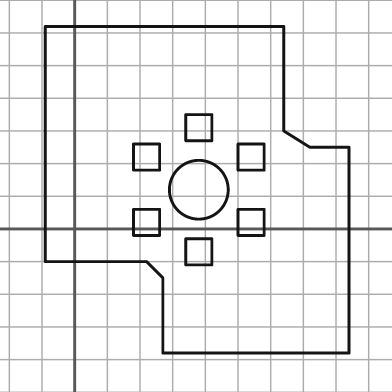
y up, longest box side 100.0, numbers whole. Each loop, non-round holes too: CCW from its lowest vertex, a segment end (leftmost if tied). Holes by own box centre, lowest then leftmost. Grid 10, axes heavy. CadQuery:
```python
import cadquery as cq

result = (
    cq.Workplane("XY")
    .moveTo(27.0, -38.0)
    .lineTo(84.0, -38.0)
    .lineTo(84.0, 25.0)
    .lineTo(72.0, 25.0)
    .lineTo(64.0, 30.0)
    .lineTo(64.0, 62.0)
    .lineTo(-9.0, 62.0)
    .lineTo(-9.0, -10.0)
    .lineTo(22.0, -10.0)
    .lineTo(27.0, -15.0)
    .close()
    .moveTo(34.0, -11.0)
    .lineTo(42.0, -11.0)
    .lineTo(42.0, -3.0)
    .lineTo(34.0, -3.0)
    .close()
    .moveTo(18.0, -2.0)
    .lineTo(26.0, -2.0)
    .lineTo(26.0, 6.0)
    .lineTo(18.0, 6.0)
    .close()
    .moveTo(50.0, -2.0)
    .lineTo(58.0, -2.0)
    .lineTo(58.0, 6.0)
    .lineTo(50.0, 6.0)
    .close()
    .moveTo(38.0, 12.0)
    .circle(9.0)
    .moveTo(18.0, 18.0)
    .lineTo(26.0, 18.0)
    .lineTo(26.0, 26.0)
    .lineTo(18.0, 26.0)
    .close()
    .moveTo(50.0, 18.0)
    .lineTo(58.0, 18.0)
    .lineTo(58.0, 26.0)
    .lineTo(50.0, 26.0)
    .close()
    .moveTo(34.0, 27.0)
    .lineTo(42.0, 27.0)
    .lineTo(42.0, 35.0)
    .lineTo(34.0, 35.0)
    .close()
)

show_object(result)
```